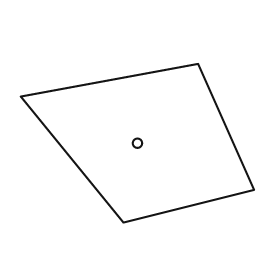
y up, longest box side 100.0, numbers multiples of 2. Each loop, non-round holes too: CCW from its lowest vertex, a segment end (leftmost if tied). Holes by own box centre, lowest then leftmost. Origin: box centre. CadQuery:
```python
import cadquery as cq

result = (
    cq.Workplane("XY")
    .moveTo(-6.0, -34.0)
    .lineTo(50.0, -20.0)
    .lineTo(26.0, 34.0)
    .lineTo(-50.0, 20.0)
    .close()
    .moveTo(0.0, 0.0)
    .circle(2.0)
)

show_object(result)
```